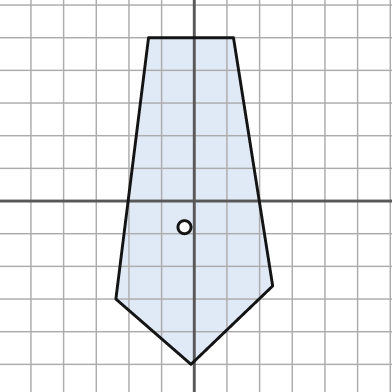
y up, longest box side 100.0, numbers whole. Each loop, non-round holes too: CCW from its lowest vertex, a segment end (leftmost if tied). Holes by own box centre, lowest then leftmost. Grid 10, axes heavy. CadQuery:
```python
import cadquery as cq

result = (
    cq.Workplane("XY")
    .moveTo(-1.0, -50.0)
    .lineTo(24.0, -26.0)
    .lineTo(12.0, 50.0)
    .lineTo(-14.0, 50.0)
    .lineTo(-24.0, -30.0)
    .close()
    .moveTo(-3.0, -8.0)
    .circle(2.0)
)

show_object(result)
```